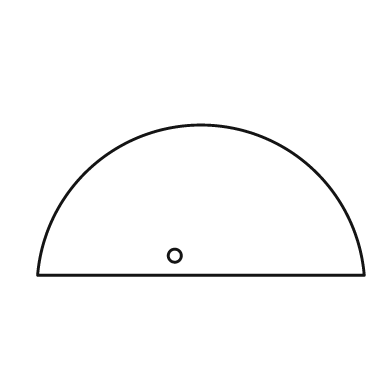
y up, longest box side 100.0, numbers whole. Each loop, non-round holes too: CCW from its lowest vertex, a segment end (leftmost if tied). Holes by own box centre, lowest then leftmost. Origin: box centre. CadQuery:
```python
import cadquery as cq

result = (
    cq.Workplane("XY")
    .moveTo(-50.0, -23.0)
    .lineTo(50.0, -23.0)
    .threePointArc((0.0, 23.0), (-50.0, -23.0))
    .close()
    .moveTo(-8.0, -17.0)
    .circle(2.0)
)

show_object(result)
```